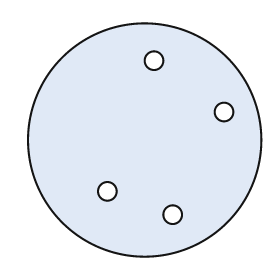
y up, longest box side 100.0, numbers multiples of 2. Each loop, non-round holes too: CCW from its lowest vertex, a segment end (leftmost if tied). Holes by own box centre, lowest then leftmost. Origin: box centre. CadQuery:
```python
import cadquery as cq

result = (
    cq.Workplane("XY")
    .moveTo(0.0, 0.0)
    .circle(50.0)
    .moveTo(12.0, -32.0)
    .circle(4.0)
    .moveTo(-16.0, -22.0)
    .circle(4.0)
    .moveTo(34.0, 12.0)
    .circle(4.0)
    .moveTo(4.0, 34.0)
    .circle(4.0)
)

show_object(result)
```